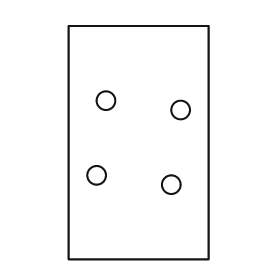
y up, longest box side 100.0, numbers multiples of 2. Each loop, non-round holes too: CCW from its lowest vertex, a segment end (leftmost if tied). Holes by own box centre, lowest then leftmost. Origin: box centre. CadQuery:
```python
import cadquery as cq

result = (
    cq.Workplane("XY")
    .moveTo(-30.0, -50.0)
    .lineTo(30.0, -50.0)
    .lineTo(30.0, 50.0)
    .lineTo(-30.0, 50.0)
    .close()
    .moveTo(14.0, -18.0)
    .circle(4.0)
    .moveTo(-18.0, -14.0)
    .circle(4.0)
    .moveTo(18.0, 14.0)
    .circle(4.0)
    .moveTo(-14.0, 18.0)
    .circle(4.0)
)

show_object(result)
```